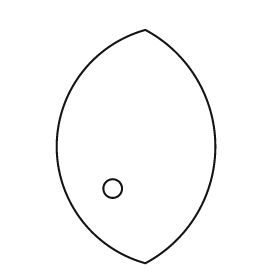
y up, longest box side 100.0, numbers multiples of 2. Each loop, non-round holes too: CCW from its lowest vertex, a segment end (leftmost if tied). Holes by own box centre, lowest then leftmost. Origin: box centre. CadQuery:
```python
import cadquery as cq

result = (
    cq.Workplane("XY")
    .moveTo(4.0, -50.0)
    .threePointArc((34.0, 0.0), (4.0, 50.0))
    .threePointArc((-34.0, 0.0), (4.0, -50.0))
    .close()
    .moveTo(-10.0, -18.0)
    .circle(4.0)
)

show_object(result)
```